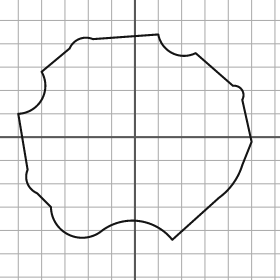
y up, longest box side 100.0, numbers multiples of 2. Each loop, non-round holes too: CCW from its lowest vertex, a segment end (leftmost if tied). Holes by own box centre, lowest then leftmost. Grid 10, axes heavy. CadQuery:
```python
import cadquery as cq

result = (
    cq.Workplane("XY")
    .moveTo(16.0, -44.0)
    .lineTo(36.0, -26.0)
    .threePointArc((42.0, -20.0), (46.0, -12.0))
    .lineTo(50.0, -2.0)
    .lineTo(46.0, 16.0)
    .threePointArc((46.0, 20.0), (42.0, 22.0))
    .lineTo(26.0, 36.0)
    .threePointArc((16.0, 36.0), (10.0, 44.0))
    .lineTo(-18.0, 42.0)
    .threePointArc((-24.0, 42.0), (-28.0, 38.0))
    .lineTo(-40.0, 28.0)
    .threePointArc((-40.0, 16.0), (-50.0, 10.0))
    .lineTo(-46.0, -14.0)
    .threePointArc((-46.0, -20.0), (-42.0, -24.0))
    .lineTo(-36.0, -30.0)
    .threePointArc((-28.0, -42.0), (-14.0, -40.0))
    .threePointArc((2.0, -36.0), (16.0, -44.0))
    .close()
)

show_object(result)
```